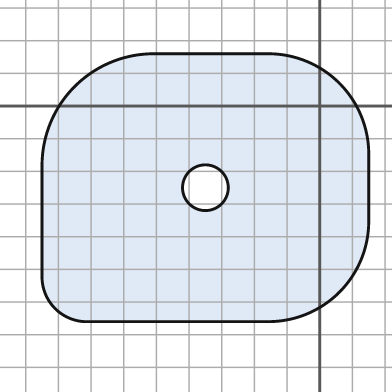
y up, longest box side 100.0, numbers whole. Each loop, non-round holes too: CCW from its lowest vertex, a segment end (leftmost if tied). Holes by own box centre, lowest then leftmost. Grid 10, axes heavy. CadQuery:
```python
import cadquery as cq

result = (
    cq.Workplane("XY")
    .moveTo(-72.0, -66.0)
    .lineTo(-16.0, -66.0)
    .threePointArc((6.0, -57.0), (15.0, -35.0))
    .lineTo(15.0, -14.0)
    .threePointArc((6.0, 7.0), (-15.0, 16.0))
    .lineTo(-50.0, 16.0)
    .threePointArc((-75.0, 6.0), (-85.0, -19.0))
    .lineTo(-85.0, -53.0)
    .threePointArc((-81.0, -62.0), (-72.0, -66.0))
    .close()
    .moveTo(-35.0, -25.0)
    .circle(7.0)
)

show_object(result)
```